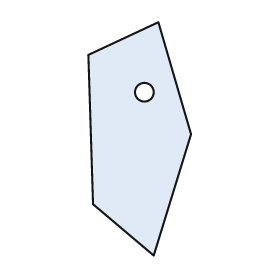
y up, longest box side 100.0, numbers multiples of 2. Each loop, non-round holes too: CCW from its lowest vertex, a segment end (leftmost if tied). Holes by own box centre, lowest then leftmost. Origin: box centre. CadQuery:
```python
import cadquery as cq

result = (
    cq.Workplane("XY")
    .moveTo(6.0, -50.0)
    .lineTo(22.0, 2.0)
    .lineTo(8.0, 50.0)
    .lineTo(-22.0, 36.0)
    .lineTo(-20.0, -28.0)
    .close()
    .moveTo(2.0, 20.0)
    .circle(4.0)
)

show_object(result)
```